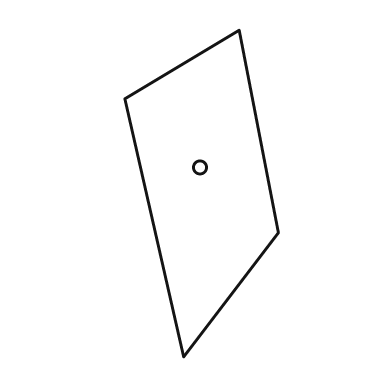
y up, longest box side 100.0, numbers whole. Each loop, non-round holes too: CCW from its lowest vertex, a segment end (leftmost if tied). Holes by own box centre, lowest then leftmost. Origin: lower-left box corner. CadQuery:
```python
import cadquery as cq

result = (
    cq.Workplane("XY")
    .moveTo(18.0, 0.0)
    .lineTo(47.0, 38.0)
    .lineTo(35.0, 100.0)
    .lineTo(0.0, 79.0)
    .close()
    .moveTo(23.0, 58.0)
    .circle(2.0)
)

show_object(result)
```